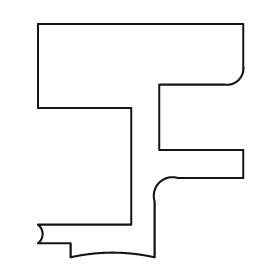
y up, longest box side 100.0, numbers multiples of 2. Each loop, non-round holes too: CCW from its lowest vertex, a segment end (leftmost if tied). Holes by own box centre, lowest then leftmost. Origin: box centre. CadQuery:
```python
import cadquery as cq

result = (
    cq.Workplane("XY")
    .moveTo(-30.0, -50.0)
    .threePointArc((-12.0, -48.0), (6.0, -50.0))
    .lineTo(6.0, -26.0)
    .threePointArc((8.0, -18.0), (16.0, -16.0))
    .lineTo(44.0, -16.0)
    .lineTo(44.0, -4.0)
    .lineTo(8.0, -4.0)
    .lineTo(8.0, 24.0)
    .lineTo(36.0, 24.0)
    .threePointArc((42.0, 26.0), (44.0, 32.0))
    .lineTo(44.0, 50.0)
    .lineTo(-44.0, 50.0)
    .lineTo(-44.0, 14.0)
    .lineTo(-4.0, 14.0)
    .lineTo(-4.0, -36.0)
    .lineTo(-44.0, -36.0)
    .threePointArc((-42.0, -40.0), (-44.0, -44.0))
    .lineTo(-30.0, -44.0)
    .close()
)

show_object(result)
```